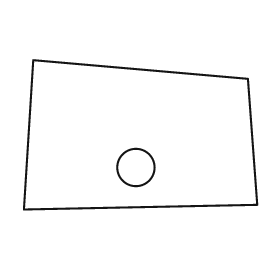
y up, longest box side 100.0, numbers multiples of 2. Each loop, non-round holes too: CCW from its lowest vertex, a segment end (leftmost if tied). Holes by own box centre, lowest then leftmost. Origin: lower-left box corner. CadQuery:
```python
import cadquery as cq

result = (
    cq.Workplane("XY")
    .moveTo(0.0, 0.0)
    .lineTo(100.0, 2.0)
    .lineTo(96.0, 56.0)
    .lineTo(4.0, 64.0)
    .close()
    .moveTo(48.0, 18.0)
    .circle(8.0)
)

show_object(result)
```